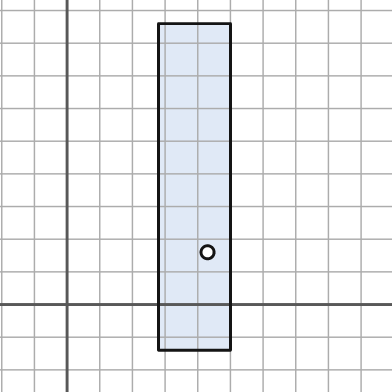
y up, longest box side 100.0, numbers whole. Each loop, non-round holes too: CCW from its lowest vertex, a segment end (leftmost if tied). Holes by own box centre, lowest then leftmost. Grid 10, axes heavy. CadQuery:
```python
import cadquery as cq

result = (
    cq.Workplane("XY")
    .moveTo(28.0, -14.0)
    .lineTo(50.0, -14.0)
    .lineTo(50.0, 86.0)
    .lineTo(28.0, 86.0)
    .close()
    .moveTo(43.0, 16.0)
    .circle(2.0)
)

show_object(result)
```